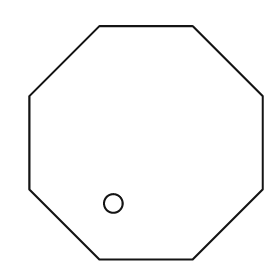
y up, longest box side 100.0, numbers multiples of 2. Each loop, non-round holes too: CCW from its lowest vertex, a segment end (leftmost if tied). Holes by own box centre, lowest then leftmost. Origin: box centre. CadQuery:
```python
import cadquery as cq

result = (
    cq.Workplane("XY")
    .moveTo(-20.0, -50.0)
    .lineTo(20.0, -50.0)
    .lineTo(50.0, -20.0)
    .lineTo(50.0, 20.0)
    .lineTo(20.0, 50.0)
    .lineTo(-20.0, 50.0)
    .lineTo(-50.0, 20.0)
    .lineTo(-50.0, -20.0)
    .close()
    .moveTo(-14.0, -26.0)
    .circle(4.0)
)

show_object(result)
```